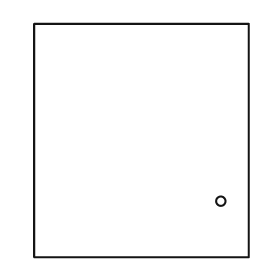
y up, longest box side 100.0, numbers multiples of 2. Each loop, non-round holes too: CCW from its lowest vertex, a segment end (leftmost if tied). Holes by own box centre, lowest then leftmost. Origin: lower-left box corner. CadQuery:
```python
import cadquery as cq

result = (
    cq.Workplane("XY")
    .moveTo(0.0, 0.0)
    .lineTo(92.0, 0.0)
    .lineTo(92.0, 100.0)
    .lineTo(0.0, 100.0)
    .close()
    .moveTo(80.0, 24.0)
    .circle(2.0)
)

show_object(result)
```